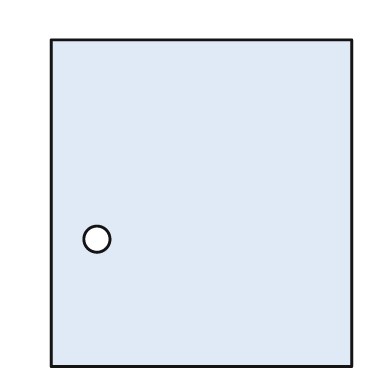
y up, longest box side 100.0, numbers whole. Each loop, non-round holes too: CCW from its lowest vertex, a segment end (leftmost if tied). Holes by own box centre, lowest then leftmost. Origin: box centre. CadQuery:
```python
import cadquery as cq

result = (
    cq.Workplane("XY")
    .moveTo(-46.0, -50.0)
    .lineTo(46.0, -50.0)
    .lineTo(46.0, 50.0)
    .lineTo(-46.0, 50.0)
    .close()
    .moveTo(-32.0, -11.0)
    .circle(4.0)
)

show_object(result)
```